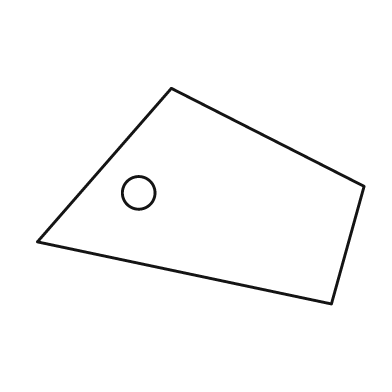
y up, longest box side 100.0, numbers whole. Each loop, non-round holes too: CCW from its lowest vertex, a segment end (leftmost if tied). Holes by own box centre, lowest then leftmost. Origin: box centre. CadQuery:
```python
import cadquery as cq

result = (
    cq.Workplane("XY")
    .moveTo(40.0, -33.0)
    .lineTo(50.0, 3.0)
    .lineTo(-9.0, 33.0)
    .lineTo(-50.0, -14.0)
    .close()
    .moveTo(-19.0, 1.0)
    .circle(5.0)
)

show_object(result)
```